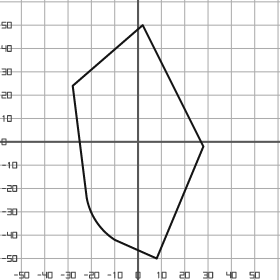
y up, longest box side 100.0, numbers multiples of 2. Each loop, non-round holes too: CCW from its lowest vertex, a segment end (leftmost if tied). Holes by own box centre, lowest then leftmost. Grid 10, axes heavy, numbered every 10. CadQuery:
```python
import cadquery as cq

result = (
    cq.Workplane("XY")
    .moveTo(8.0, -50.0)
    .lineTo(28.0, -2.0)
    .lineTo(2.0, 50.0)
    .lineTo(-28.0, 24.0)
    .lineTo(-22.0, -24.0)
    .threePointArc((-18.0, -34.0), (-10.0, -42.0))
    .close()
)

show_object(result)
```